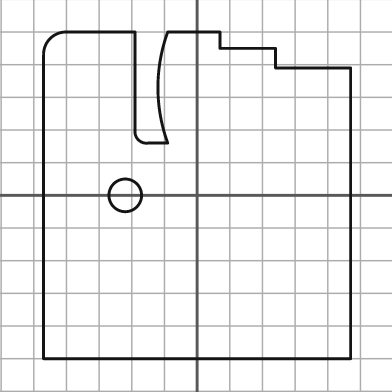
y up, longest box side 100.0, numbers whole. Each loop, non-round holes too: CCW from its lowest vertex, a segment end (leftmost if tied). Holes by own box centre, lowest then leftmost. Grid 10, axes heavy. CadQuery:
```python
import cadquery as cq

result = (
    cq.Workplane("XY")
    .moveTo(-47.0, -50.0)
    .lineTo(47.0, -50.0)
    .lineTo(47.0, 39.0)
    .lineTo(24.0, 39.0)
    .lineTo(24.0, 45.0)
    .lineTo(7.0, 45.0)
    .lineTo(7.0, 50.0)
    .lineTo(-9.0, 50.0)
    .threePointArc((-12.0, 33.0), (-9.0, 16.0))
    .lineTo(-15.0, 16.0)
    .threePointArc((-18.0, 17.0), (-19.0, 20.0))
    .lineTo(-19.0, 50.0)
    .lineTo(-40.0, 50.0)
    .threePointArc((-45.0, 48.0), (-47.0, 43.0))
    .close()
    .moveTo(-22.0, 0.0)
    .circle(5.0)
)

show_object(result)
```